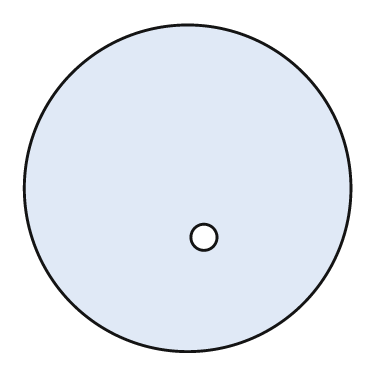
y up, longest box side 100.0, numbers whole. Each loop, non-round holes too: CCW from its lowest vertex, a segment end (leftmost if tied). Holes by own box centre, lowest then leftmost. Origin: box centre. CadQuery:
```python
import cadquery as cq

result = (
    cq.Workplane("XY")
    .moveTo(0.0, 0.0)
    .circle(50.0)
    .moveTo(5.0, -15.0)
    .circle(4.0)
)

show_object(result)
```